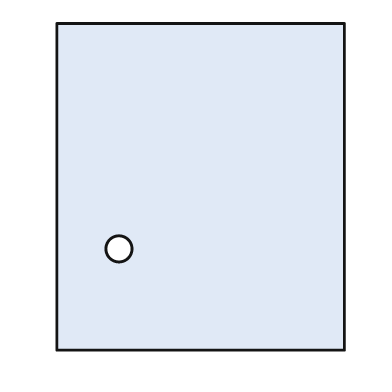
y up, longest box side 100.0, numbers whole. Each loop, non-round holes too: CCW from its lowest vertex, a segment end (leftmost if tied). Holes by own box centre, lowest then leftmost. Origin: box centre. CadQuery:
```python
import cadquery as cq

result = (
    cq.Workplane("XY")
    .moveTo(-44.0, -50.0)
    .lineTo(44.0, -50.0)
    .lineTo(44.0, 50.0)
    .lineTo(-44.0, 50.0)
    .close()
    .moveTo(-25.0, -19.0)
    .circle(4.0)
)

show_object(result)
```